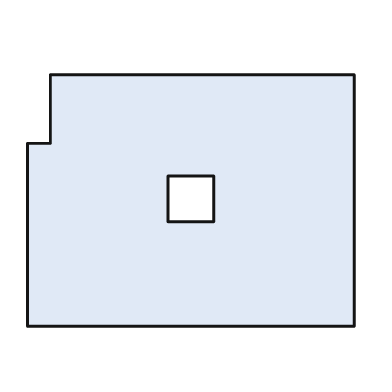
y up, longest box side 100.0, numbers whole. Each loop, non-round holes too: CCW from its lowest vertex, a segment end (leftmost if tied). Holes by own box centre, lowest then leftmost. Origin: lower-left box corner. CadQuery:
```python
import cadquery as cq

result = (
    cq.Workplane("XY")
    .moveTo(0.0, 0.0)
    .lineTo(100.0, 0.0)
    .lineTo(100.0, 77.0)
    .lineTo(7.0, 77.0)
    .lineTo(7.0, 56.0)
    .lineTo(0.0, 56.0)
    .close()
    .moveTo(43.0, 32.0)
    .lineTo(57.0, 32.0)
    .lineTo(57.0, 46.0)
    .lineTo(43.0, 46.0)
    .close()
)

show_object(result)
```